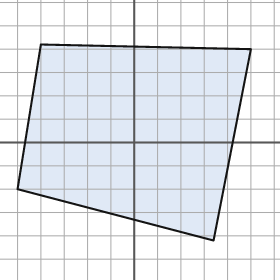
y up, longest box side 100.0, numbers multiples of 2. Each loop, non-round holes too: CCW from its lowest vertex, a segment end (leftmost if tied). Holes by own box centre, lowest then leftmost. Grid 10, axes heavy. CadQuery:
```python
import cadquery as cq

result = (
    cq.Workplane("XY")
    .moveTo(34.0, -42.0)
    .lineTo(50.0, 40.0)
    .lineTo(-40.0, 42.0)
    .lineTo(-50.0, -20.0)
    .close()
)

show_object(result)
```